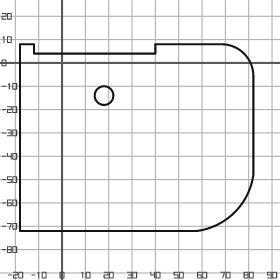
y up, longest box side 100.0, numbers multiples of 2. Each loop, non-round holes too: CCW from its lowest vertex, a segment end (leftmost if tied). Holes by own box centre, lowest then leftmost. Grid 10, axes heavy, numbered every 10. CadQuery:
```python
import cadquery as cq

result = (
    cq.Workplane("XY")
    .moveTo(-18.0, -72.0)
    .lineTo(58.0, -72.0)
    .threePointArc((74.0, -64.0), (82.0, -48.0))
    .lineTo(82.0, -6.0)
    .threePointArc((78.0, 4.0), (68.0, 8.0))
    .lineTo(40.0, 8.0)
    .lineTo(40.0, 4.0)
    .lineTo(-12.0, 4.0)
    .lineTo(-12.0, 8.0)
    .lineTo(-18.0, 8.0)
    .close()
    .moveTo(18.0, -14.0)
    .circle(4.0)
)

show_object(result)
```